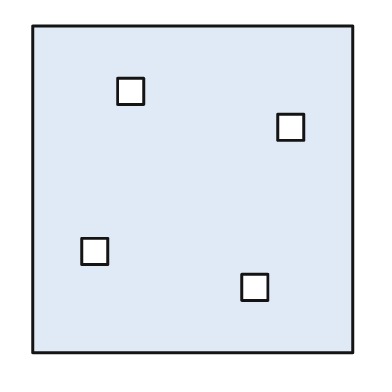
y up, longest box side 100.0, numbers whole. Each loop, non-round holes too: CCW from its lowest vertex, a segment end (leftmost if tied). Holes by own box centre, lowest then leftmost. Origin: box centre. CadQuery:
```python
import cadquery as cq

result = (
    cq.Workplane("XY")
    .moveTo(-49.0, -50.0)
    .lineTo(49.0, -50.0)
    .lineTo(49.0, 50.0)
    .lineTo(-49.0, 50.0)
    .close()
    .moveTo(15.0, -34.0)
    .lineTo(23.0, -34.0)
    .lineTo(23.0, -26.0)
    .lineTo(15.0, -26.0)
    .close()
    .moveTo(-34.0, -23.0)
    .lineTo(-26.0, -23.0)
    .lineTo(-26.0, -15.0)
    .lineTo(-34.0, -15.0)
    .close()
    .moveTo(26.0, 15.0)
    .lineTo(34.0, 15.0)
    .lineTo(34.0, 23.0)
    .lineTo(26.0, 23.0)
    .close()
    .moveTo(-23.0, 26.0)
    .lineTo(-15.0, 26.0)
    .lineTo(-15.0, 34.0)
    .lineTo(-23.0, 34.0)
    .close()
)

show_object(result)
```